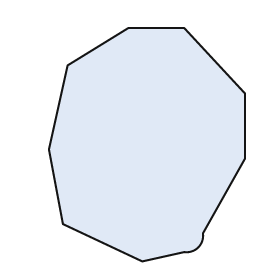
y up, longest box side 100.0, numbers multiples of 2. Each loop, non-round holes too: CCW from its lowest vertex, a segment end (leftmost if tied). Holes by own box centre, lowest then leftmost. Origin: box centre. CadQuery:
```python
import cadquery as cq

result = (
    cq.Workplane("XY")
    .moveTo(-2.0, -50.0)
    .lineTo(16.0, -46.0)
    .threePointArc((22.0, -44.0), (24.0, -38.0))
    .lineTo(42.0, -6.0)
    .lineTo(42.0, 22.0)
    .lineTo(16.0, 50.0)
    .lineTo(-8.0, 50.0)
    .lineTo(-34.0, 34.0)
    .lineTo(-42.0, -2.0)
    .lineTo(-36.0, -34.0)
    .close()
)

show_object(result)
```